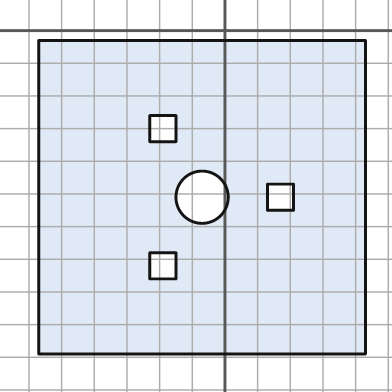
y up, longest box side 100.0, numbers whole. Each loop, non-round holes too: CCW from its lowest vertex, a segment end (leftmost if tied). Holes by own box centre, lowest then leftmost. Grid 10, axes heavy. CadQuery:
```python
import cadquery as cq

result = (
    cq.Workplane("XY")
    .moveTo(-57.0, -99.0)
    .lineTo(43.0, -99.0)
    .lineTo(43.0, -3.0)
    .lineTo(-57.0, -3.0)
    .close()
    .moveTo(-23.0, -76.0)
    .lineTo(-15.0, -76.0)
    .lineTo(-15.0, -68.0)
    .lineTo(-23.0, -68.0)
    .close()
    .moveTo(-7.0, -51.0)
    .circle(8.0)
    .moveTo(13.0, -55.0)
    .lineTo(21.0, -55.0)
    .lineTo(21.0, -47.0)
    .lineTo(13.0, -47.0)
    .close()
    .moveTo(-23.0, -34.0)
    .lineTo(-15.0, -34.0)
    .lineTo(-15.0, -26.0)
    .lineTo(-23.0, -26.0)
    .close()
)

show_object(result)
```